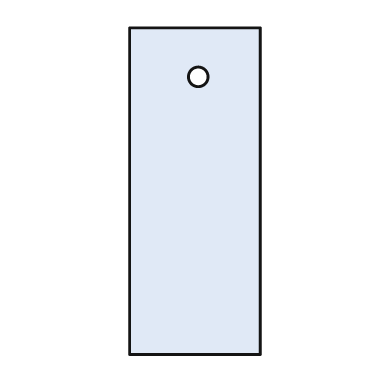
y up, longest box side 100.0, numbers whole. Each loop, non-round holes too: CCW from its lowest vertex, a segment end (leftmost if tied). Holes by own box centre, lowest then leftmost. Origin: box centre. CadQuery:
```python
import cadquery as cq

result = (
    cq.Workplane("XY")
    .moveTo(-20.0, -50.0)
    .lineTo(20.0, -50.0)
    .lineTo(20.0, 50.0)
    .lineTo(-20.0, 50.0)
    .close()
    .moveTo(1.0, 35.0)
    .circle(3.0)
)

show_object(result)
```